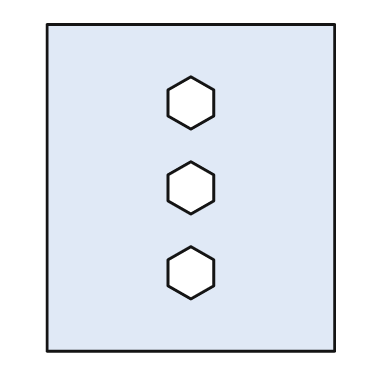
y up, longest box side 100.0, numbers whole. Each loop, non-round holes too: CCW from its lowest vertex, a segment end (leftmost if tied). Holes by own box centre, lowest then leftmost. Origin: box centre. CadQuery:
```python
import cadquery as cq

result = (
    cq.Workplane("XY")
    .moveTo(-44.0, -50.0)
    .lineTo(44.0, -50.0)
    .lineTo(44.0, 50.0)
    .lineTo(-44.0, 50.0)
    .close()
    .moveTo(0.0, -34.0)
    .lineTo(7.0, -30.0)
    .lineTo(7.0, -22.0)
    .lineTo(0.0, -18.0)
    .lineTo(-7.0, -22.0)
    .lineTo(-7.0, -30.0)
    .close()
    .moveTo(0.0, -8.0)
    .lineTo(7.0, -4.0)
    .lineTo(7.0, 4.0)
    .lineTo(0.0, 8.0)
    .lineTo(-7.0, 4.0)
    .lineTo(-7.0, -4.0)
    .close()
    .moveTo(0.0, 18.0)
    .lineTo(7.0, 22.0)
    .lineTo(7.0, 30.0)
    .lineTo(0.0, 34.0)
    .lineTo(-7.0, 30.0)
    .lineTo(-7.0, 22.0)
    .close()
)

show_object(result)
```